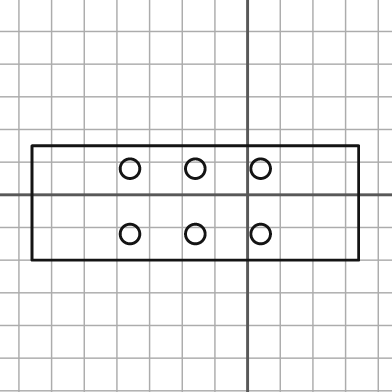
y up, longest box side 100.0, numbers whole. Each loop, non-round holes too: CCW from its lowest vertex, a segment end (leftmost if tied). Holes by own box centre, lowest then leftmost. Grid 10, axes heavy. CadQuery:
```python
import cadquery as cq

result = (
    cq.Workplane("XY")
    .moveTo(-66.0, -20.0)
    .lineTo(34.0, -20.0)
    .lineTo(34.0, 15.0)
    .lineTo(-66.0, 15.0)
    .close()
    .moveTo(-36.0, -12.0)
    .circle(3.0)
    .moveTo(-16.0, -12.0)
    .circle(3.0)
    .moveTo(4.0, -12.0)
    .circle(3.0)
    .moveTo(-36.0, 8.0)
    .circle(3.0)
    .moveTo(-16.0, 8.0)
    .circle(3.0)
    .moveTo(4.0, 8.0)
    .circle(3.0)
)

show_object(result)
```